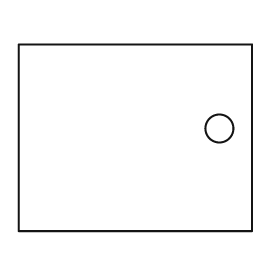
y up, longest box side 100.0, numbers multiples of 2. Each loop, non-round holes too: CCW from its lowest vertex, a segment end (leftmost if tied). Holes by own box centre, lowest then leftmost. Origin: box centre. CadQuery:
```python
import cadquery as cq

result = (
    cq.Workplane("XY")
    .moveTo(-50.0, -40.0)
    .lineTo(50.0, -40.0)
    .lineTo(50.0, 40.0)
    .lineTo(-50.0, 40.0)
    .close()
    .moveTo(36.0, 4.0)
    .circle(6.0)
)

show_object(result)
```